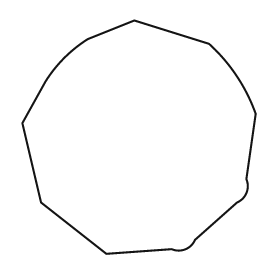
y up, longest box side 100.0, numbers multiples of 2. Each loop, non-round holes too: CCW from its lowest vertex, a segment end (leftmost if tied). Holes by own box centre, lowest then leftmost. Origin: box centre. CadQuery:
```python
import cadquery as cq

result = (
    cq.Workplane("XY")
    .moveTo(-14.0, -50.0)
    .lineTo(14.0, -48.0)
    .threePointArc((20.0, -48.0), (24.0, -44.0))
    .lineTo(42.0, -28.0)
    .threePointArc((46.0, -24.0), (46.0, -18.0))
    .lineTo(50.0, 10.0)
    .threePointArc((42.0, 26.0), (30.0, 40.0))
    .lineTo(-2.0, 50.0)
    .lineTo(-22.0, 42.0)
    .threePointArc((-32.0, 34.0), (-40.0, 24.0))
    .lineTo(-50.0, 6.0)
    .lineTo(-42.0, -28.0)
    .close()
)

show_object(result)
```